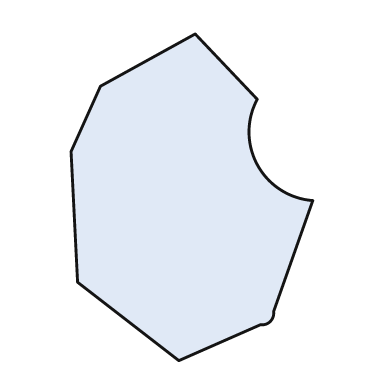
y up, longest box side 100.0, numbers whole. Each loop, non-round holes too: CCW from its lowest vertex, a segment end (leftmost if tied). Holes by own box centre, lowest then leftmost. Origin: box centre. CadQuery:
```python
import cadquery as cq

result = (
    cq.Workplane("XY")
    .moveTo(-4.0, -50.0)
    .lineTo(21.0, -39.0)
    .threePointArc((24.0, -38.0), (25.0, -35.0))
    .lineTo(37.0, -1.0)
    .threePointArc((20.0, 10.0), (20.0, 30.0))
    .lineTo(1.0, 50.0)
    .lineTo(-28.0, 34.0)
    .lineTo(-37.0, 14.0)
    .lineTo(-35.0, -26.0)
    .close()
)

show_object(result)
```